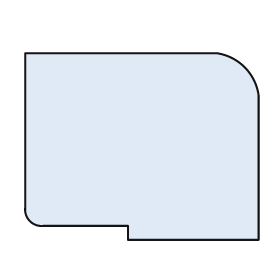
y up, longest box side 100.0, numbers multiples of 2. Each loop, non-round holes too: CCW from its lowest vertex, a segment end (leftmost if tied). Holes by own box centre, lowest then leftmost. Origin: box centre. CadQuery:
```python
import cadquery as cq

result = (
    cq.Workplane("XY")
    .moveTo(-6.0, -40.0)
    .lineTo(50.0, -40.0)
    .lineTo(50.0, 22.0)
    .threePointArc((44.0, 34.0), (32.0, 40.0))
    .lineTo(-50.0, 40.0)
    .lineTo(-50.0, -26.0)
    .threePointArc((-48.0, -32.0), (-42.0, -34.0))
    .lineTo(-6.0, -34.0)
    .close()
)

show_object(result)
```